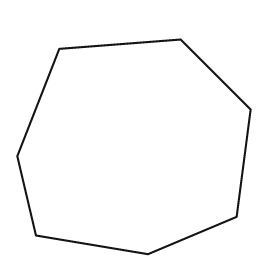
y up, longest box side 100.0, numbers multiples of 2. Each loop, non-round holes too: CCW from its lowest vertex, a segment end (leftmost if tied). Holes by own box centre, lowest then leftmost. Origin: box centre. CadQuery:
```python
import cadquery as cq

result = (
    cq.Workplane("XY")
    .moveTo(6.0, -46.0)
    .lineTo(44.0, -30.0)
    .lineTo(50.0, 16.0)
    .lineTo(20.0, 46.0)
    .lineTo(-32.0, 42.0)
    .lineTo(-50.0, -4.0)
    .lineTo(-42.0, -38.0)
    .close()
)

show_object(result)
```